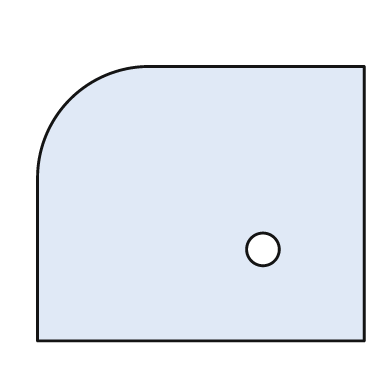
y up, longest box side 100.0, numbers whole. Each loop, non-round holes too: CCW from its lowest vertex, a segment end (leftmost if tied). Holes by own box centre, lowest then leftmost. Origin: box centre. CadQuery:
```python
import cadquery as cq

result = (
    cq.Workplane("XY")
    .moveTo(-50.0, -42.0)
    .lineTo(50.0, -42.0)
    .lineTo(50.0, 42.0)
    .lineTo(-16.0, 42.0)
    .threePointArc((-40.0, 32.0), (-50.0, 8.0))
    .close()
    .moveTo(19.0, -14.0)
    .circle(5.0)
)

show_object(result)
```